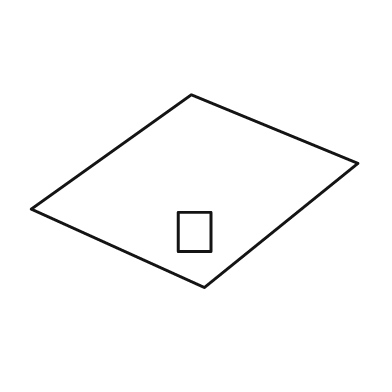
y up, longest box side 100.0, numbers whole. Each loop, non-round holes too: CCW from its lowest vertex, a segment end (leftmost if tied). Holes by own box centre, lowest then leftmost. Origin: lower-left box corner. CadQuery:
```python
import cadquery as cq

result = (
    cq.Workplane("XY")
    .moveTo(53.0, 0.0)
    .lineTo(100.0, 38.0)
    .lineTo(49.0, 59.0)
    .lineTo(0.0, 24.0)
    .close()
    .moveTo(45.0, 11.0)
    .lineTo(55.0, 11.0)
    .lineTo(55.0, 23.0)
    .lineTo(45.0, 23.0)
    .close()
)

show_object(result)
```